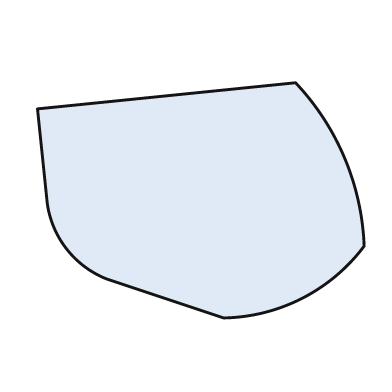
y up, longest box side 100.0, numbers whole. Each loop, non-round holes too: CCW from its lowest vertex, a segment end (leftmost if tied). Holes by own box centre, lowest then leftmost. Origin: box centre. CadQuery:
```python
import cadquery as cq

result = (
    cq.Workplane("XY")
    .moveTo(7.0, -36.0)
    .threePointArc((31.0, -30.0), (50.0, -14.0))
    .threePointArc((44.0, 13.0), (29.0, 36.0))
    .lineTo(-50.0, 28.0)
    .lineTo(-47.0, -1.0)
    .threePointArc((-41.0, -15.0), (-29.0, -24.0))
    .close()
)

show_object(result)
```